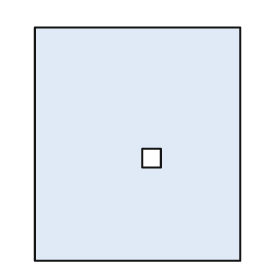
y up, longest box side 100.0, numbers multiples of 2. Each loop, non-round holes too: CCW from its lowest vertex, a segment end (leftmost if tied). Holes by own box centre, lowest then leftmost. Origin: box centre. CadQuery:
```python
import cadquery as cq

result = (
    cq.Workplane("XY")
    .moveTo(-44.0, -50.0)
    .lineTo(44.0, -50.0)
    .lineTo(44.0, 50.0)
    .lineTo(-44.0, 50.0)
    .close()
    .moveTo(2.0, -10.0)
    .lineTo(10.0, -10.0)
    .lineTo(10.0, -2.0)
    .lineTo(2.0, -2.0)
    .close()
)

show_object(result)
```